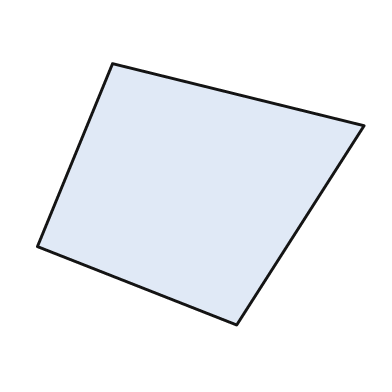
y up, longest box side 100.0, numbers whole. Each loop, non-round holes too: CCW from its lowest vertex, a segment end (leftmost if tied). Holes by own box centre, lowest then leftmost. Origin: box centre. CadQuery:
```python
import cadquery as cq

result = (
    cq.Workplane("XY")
    .moveTo(11.0, -40.0)
    .lineTo(50.0, 21.0)
    .lineTo(-27.0, 40.0)
    .lineTo(-50.0, -16.0)
    .close()
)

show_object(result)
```